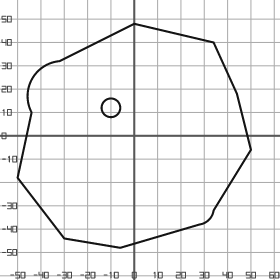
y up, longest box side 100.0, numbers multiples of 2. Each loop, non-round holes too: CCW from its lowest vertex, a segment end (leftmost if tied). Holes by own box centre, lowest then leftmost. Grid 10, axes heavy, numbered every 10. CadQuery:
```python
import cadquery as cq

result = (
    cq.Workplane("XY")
    .moveTo(-6.0, -48.0)
    .lineTo(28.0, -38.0)
    .threePointArc((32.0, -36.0), (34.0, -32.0))
    .lineTo(50.0, -6.0)
    .lineTo(44.0, 18.0)
    .lineTo(34.0, 40.0)
    .lineTo(0.0, 48.0)
    .lineTo(-32.0, 32.0)
    .threePointArc((-44.0, 24.0), (-44.0, 10.0))
    .lineTo(-50.0, -18.0)
    .lineTo(-30.0, -44.0)
    .close()
    .moveTo(-10.0, 12.0)
    .circle(4.0)
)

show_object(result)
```